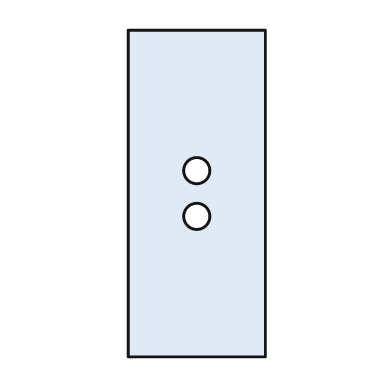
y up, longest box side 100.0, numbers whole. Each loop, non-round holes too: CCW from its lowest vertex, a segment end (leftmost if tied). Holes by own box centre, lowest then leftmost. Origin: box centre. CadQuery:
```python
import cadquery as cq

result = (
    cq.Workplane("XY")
    .moveTo(-21.0, -50.0)
    .lineTo(21.0, -50.0)
    .lineTo(21.0, 50.0)
    .lineTo(-21.0, 50.0)
    .close()
    .moveTo(0.0, -7.0)
    .circle(4.0)
    .moveTo(0.0, 7.0)
    .circle(4.0)
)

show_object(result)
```